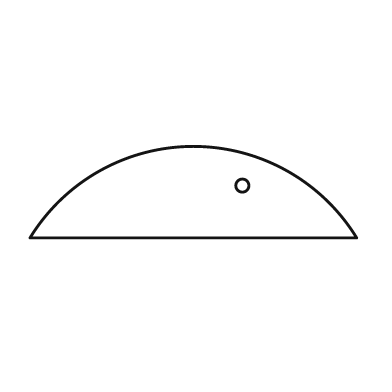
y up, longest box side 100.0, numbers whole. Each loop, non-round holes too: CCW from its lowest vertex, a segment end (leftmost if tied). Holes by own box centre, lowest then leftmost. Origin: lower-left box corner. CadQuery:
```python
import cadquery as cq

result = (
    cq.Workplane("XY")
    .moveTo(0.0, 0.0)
    .lineTo(100.0, 0.0)
    .threePointArc((50.0, 28.0), (0.0, 0.0))
    .close()
    .moveTo(65.0, 16.0)
    .circle(2.0)
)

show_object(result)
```